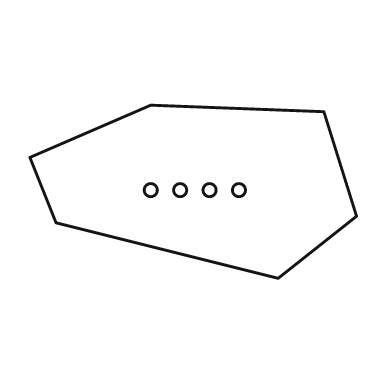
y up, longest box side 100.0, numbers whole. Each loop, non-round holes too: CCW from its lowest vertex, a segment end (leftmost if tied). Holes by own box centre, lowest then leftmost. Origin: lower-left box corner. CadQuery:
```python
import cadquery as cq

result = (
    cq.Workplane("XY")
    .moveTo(76.0, 0.0)
    .lineTo(100.0, 19.0)
    .lineTo(90.0, 51.0)
    .lineTo(37.0, 53.0)
    .lineTo(0.0, 37.0)
    .lineTo(8.0, 17.0)
    .close()
    .moveTo(37.0, 27.0)
    .circle(2.0)
    .moveTo(46.0, 27.0)
    .circle(2.0)
    .moveTo(55.0, 27.0)
    .circle(2.0)
    .moveTo(64.0, 27.0)
    .circle(2.0)
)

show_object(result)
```